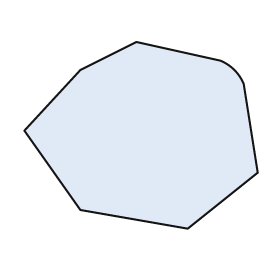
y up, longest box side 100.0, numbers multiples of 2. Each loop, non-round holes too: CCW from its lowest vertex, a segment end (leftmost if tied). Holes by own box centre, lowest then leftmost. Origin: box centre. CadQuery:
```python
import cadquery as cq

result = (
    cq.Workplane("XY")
    .moveTo(20.0, -40.0)
    .lineTo(50.0, -16.0)
    .lineTo(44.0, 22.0)
    .threePointArc((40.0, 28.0), (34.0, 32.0))
    .lineTo(-2.0, 40.0)
    .lineTo(-26.0, 28.0)
    .lineTo(-50.0, 2.0)
    .lineTo(-26.0, -32.0)
    .close()
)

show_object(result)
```